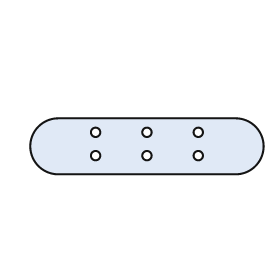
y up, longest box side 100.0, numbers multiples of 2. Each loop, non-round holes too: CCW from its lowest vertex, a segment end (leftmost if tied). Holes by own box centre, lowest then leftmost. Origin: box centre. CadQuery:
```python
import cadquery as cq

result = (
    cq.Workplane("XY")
    .moveTo(-38.0, -12.0)
    .lineTo(38.0, -12.0)
    .threePointArc((50.0, 0.0), (38.0, 12.0))
    .lineTo(-38.0, 12.0)
    .threePointArc((-50.0, 0.0), (-38.0, -12.0))
    .close()
    .moveTo(-22.0, -4.0)
    .circle(2.0)
    .moveTo(0.0, -4.0)
    .circle(2.0)
    .moveTo(22.0, -4.0)
    .circle(2.0)
    .moveTo(-22.0, 6.0)
    .circle(2.0)
    .moveTo(0.0, 6.0)
    .circle(2.0)
    .moveTo(22.0, 6.0)
    .circle(2.0)
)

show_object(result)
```